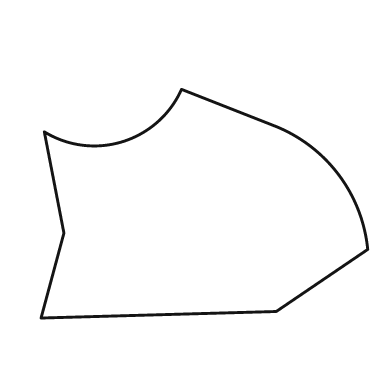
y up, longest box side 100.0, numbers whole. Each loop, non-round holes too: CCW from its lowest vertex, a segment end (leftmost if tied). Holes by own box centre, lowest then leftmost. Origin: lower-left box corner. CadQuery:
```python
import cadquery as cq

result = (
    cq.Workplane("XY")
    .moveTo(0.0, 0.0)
    .lineTo(72.0, 2.0)
    .lineTo(100.0, 21.0)
    .threePointArc((91.0, 44.0), (71.0, 59.0))
    .lineTo(43.0, 70.0)
    .threePointArc((25.0, 54.0), (1.0, 57.0))
    .lineTo(7.0, 26.0)
    .close()
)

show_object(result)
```